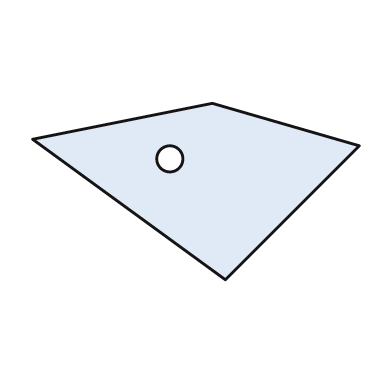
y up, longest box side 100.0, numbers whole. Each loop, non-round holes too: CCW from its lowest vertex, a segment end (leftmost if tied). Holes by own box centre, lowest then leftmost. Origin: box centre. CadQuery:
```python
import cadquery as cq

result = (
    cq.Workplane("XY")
    .moveTo(9.0, -27.0)
    .lineTo(50.0, 14.0)
    .lineTo(5.0, 27.0)
    .lineTo(-50.0, 16.0)
    .close()
    .moveTo(-8.0, 10.0)
    .circle(4.0)
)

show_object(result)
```